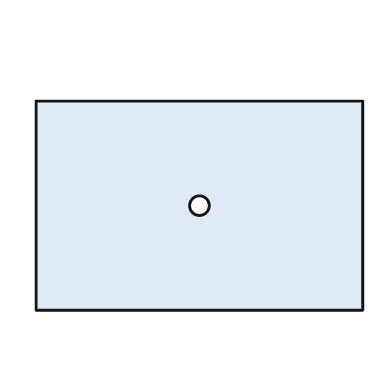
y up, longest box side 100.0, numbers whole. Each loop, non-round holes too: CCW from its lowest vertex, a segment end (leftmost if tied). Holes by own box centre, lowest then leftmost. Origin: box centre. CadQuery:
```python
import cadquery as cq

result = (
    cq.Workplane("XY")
    .moveTo(-50.0, -32.0)
    .lineTo(50.0, -32.0)
    .lineTo(50.0, 32.0)
    .lineTo(-50.0, 32.0)
    .close()
    .moveTo(0.0, 0.0)
    .circle(3.0)
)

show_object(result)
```